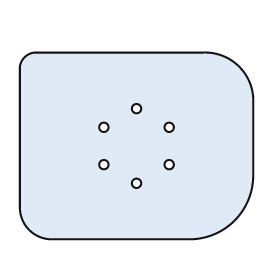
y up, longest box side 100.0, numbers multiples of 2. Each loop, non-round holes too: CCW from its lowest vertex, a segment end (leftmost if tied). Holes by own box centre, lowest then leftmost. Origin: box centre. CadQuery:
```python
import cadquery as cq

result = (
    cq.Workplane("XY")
    .moveTo(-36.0, -40.0)
    .lineTo(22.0, -40.0)
    .threePointArc((42.0, -32.0), (50.0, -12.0))
    .lineTo(50.0, 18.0)
    .threePointArc((44.0, 34.0), (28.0, 40.0))
    .lineTo(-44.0, 40.0)
    .threePointArc((-48.0, 38.0), (-50.0, 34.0))
    .lineTo(-50.0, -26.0)
    .threePointArc((-46.0, -36.0), (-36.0, -40.0))
    .close()
    .moveTo(0.0, -16.0)
    .circle(2.0)
    .moveTo(-14.0, -8.0)
    .circle(2.0)
    .moveTo(14.0, -8.0)
    .circle(2.0)
    .moveTo(-14.0, 8.0)
    .circle(2.0)
    .moveTo(14.0, 8.0)
    .circle(2.0)
    .moveTo(0.0, 16.0)
    .circle(2.0)
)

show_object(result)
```